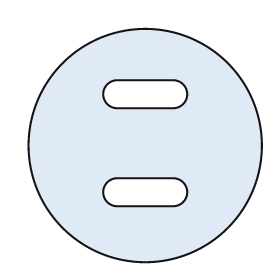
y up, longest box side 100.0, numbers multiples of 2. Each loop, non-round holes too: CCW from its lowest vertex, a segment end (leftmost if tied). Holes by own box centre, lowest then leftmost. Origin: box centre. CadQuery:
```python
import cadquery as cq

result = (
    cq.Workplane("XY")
    .moveTo(0.0, 0.0)
    .circle(50.0)
    .moveTo(-12.0, -26.0)
    .lineTo(12.0, -26.0)
    .threePointArc((18.0, -20.0), (12.0, -14.0))
    .lineTo(-12.0, -14.0)
    .threePointArc((-18.0, -20.0), (-12.0, -26.0))
    .close()
    .moveTo(-12.0, 16.0)
    .lineTo(12.0, 16.0)
    .threePointArc((18.0, 22.0), (12.0, 28.0))
    .lineTo(-12.0, 28.0)
    .threePointArc((-18.0, 22.0), (-12.0, 16.0))
    .close()
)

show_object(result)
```